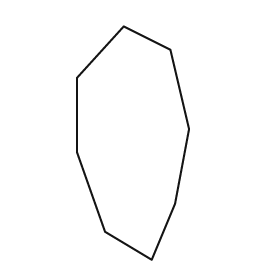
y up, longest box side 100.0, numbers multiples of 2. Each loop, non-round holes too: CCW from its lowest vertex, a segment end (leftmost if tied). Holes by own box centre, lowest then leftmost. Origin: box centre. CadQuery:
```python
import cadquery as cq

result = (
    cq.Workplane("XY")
    .moveTo(8.0, -50.0)
    .lineTo(18.0, -26.0)
    .lineTo(24.0, 6.0)
    .lineTo(16.0, 40.0)
    .lineTo(-4.0, 50.0)
    .lineTo(-24.0, 28.0)
    .lineTo(-24.0, -4.0)
    .lineTo(-12.0, -38.0)
    .close()
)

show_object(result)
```